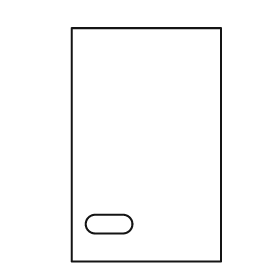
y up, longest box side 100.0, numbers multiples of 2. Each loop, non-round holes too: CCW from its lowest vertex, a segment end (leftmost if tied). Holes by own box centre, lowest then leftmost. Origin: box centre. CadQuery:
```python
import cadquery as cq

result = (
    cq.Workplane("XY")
    .moveTo(-32.0, -50.0)
    .lineTo(32.0, -50.0)
    .lineTo(32.0, 50.0)
    .lineTo(-32.0, 50.0)
    .close()
    .moveTo(-22.0, -38.0)
    .lineTo(-10.0, -38.0)
    .threePointArc((-6.0, -34.0), (-10.0, -30.0))
    .lineTo(-22.0, -30.0)
    .threePointArc((-26.0, -34.0), (-22.0, -38.0))
    .close()
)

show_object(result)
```